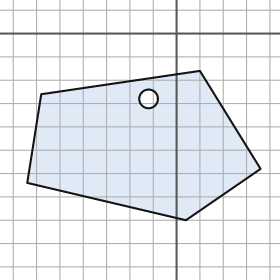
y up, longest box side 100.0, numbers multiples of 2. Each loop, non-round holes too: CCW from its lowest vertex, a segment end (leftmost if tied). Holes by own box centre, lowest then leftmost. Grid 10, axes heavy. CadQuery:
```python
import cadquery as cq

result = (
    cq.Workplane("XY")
    .moveTo(4.0, -80.0)
    .lineTo(36.0, -58.0)
    .lineTo(10.0, -16.0)
    .lineTo(-58.0, -26.0)
    .lineTo(-64.0, -64.0)
    .close()
    .moveTo(-12.0, -28.0)
    .circle(4.0)
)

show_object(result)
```